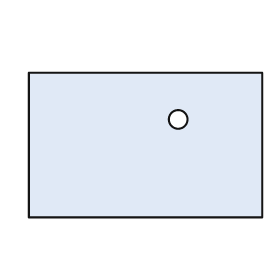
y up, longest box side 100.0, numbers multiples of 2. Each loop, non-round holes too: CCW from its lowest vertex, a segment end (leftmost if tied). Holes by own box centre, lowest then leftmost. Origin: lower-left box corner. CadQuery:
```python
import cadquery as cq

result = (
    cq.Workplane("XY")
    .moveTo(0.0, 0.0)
    .lineTo(100.0, 0.0)
    .lineTo(100.0, 62.0)
    .lineTo(0.0, 62.0)
    .close()
    .moveTo(64.0, 42.0)
    .circle(4.0)
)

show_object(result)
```